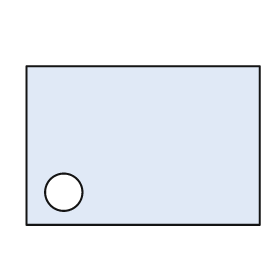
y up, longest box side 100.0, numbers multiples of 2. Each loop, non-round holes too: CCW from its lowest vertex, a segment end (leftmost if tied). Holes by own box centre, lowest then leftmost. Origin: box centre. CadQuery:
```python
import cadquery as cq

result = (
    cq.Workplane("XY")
    .moveTo(-50.0, -34.0)
    .lineTo(50.0, -34.0)
    .lineTo(50.0, 34.0)
    .lineTo(-50.0, 34.0)
    .close()
    .moveTo(-34.0, -20.0)
    .circle(8.0)
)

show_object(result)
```